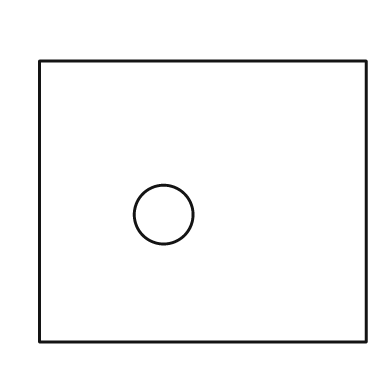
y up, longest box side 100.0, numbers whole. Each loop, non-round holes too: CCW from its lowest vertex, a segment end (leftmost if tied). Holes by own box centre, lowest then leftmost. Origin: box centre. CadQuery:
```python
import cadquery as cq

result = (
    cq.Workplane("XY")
    .moveTo(-50.0, -43.0)
    .lineTo(50.0, -43.0)
    .lineTo(50.0, 43.0)
    .lineTo(-50.0, 43.0)
    .close()
    .moveTo(-12.0, -4.0)
    .circle(9.0)
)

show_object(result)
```